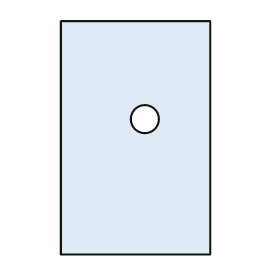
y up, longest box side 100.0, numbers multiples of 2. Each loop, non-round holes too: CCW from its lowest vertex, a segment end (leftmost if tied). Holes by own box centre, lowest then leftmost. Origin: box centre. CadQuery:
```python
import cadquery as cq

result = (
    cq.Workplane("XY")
    .moveTo(-32.0, -50.0)
    .lineTo(32.0, -50.0)
    .lineTo(32.0, 50.0)
    .lineTo(-32.0, 50.0)
    .close()
    .moveTo(4.0, 8.0)
    .circle(6.0)
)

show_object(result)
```